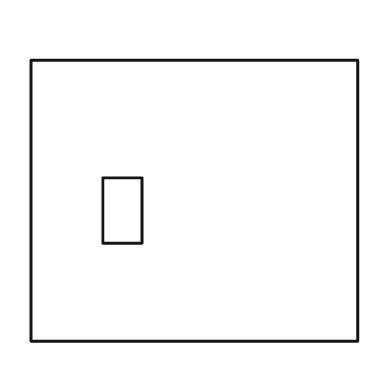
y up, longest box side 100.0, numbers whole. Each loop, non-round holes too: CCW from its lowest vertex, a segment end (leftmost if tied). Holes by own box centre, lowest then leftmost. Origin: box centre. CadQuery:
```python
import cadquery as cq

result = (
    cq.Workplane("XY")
    .moveTo(-50.0, -43.0)
    .lineTo(50.0, -43.0)
    .lineTo(50.0, 43.0)
    .lineTo(-50.0, 43.0)
    .close()
    .moveTo(-28.0, -13.0)
    .lineTo(-16.0, -13.0)
    .lineTo(-16.0, 7.0)
    .lineTo(-28.0, 7.0)
    .close()
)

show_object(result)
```